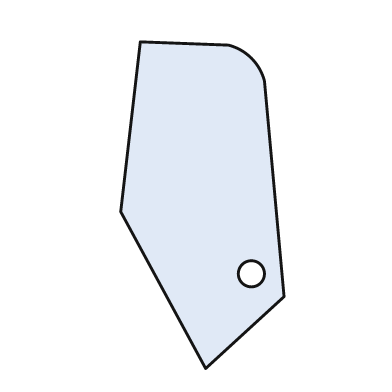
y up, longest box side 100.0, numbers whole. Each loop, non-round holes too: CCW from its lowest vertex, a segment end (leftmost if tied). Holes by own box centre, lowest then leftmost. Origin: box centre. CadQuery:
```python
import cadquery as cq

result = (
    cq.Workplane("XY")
    .moveTo(1.0, -50.0)
    .lineTo(25.0, -28.0)
    .lineTo(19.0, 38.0)
    .threePointArc((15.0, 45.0), (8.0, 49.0))
    .lineTo(-19.0, 50.0)
    .lineTo(-25.0, -2.0)
    .close()
    .moveTo(15.0, -21.0)
    .circle(4.0)
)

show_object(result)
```